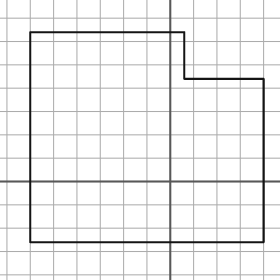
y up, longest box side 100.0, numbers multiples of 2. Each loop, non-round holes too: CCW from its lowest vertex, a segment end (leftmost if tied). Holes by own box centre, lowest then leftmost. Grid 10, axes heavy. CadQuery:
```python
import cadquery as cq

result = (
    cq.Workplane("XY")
    .moveTo(-60.0, -26.0)
    .lineTo(40.0, -26.0)
    .lineTo(40.0, 44.0)
    .lineTo(6.0, 44.0)
    .lineTo(6.0, 64.0)
    .lineTo(-60.0, 64.0)
    .close()
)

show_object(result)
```